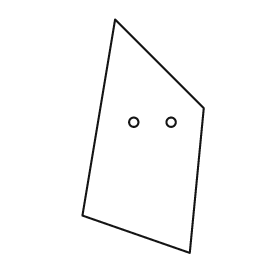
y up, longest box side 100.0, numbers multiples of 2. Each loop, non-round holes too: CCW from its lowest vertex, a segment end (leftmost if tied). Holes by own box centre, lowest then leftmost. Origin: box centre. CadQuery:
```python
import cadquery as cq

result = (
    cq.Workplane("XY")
    .moveTo(20.0, -50.0)
    .lineTo(26.0, 12.0)
    .lineTo(-12.0, 50.0)
    .lineTo(-26.0, -34.0)
    .close()
    .moveTo(-4.0, 6.0)
    .circle(2.0)
    .moveTo(12.0, 6.0)
    .circle(2.0)
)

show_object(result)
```